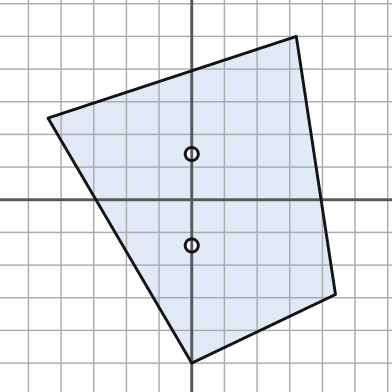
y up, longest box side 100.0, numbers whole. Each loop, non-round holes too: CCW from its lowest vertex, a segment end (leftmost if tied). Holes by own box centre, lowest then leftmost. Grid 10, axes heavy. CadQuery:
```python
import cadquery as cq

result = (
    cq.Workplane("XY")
    .moveTo(0.0, -50.0)
    .lineTo(44.0, -29.0)
    .lineTo(32.0, 50.0)
    .lineTo(-44.0, 25.0)
    .close()
    .moveTo(0.0, -14.0)
    .circle(2.0)
    .moveTo(0.0, 14.0)
    .circle(2.0)
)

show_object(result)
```